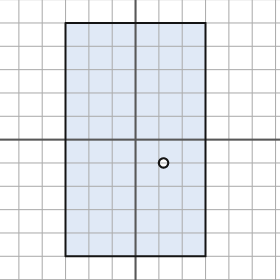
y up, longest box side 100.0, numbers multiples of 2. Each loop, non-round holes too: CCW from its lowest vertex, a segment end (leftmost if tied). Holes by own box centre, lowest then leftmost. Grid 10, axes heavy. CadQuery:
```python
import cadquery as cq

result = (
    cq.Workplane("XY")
    .moveTo(-30.0, -50.0)
    .lineTo(30.0, -50.0)
    .lineTo(30.0, 50.0)
    .lineTo(-30.0, 50.0)
    .close()
    .moveTo(12.0, -10.0)
    .circle(2.0)
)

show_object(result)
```